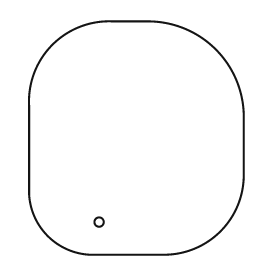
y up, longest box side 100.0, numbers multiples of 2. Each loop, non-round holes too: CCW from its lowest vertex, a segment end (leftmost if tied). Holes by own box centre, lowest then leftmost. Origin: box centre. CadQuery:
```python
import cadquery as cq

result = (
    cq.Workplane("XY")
    .moveTo(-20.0, -50.0)
    .lineTo(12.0, -50.0)
    .threePointArc((36.0, -40.0), (46.0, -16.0))
    .lineTo(46.0, 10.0)
    .threePointArc((34.0, 38.0), (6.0, 50.0))
    .lineTo(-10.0, 50.0)
    .threePointArc((-36.0, 40.0), (-46.0, 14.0))
    .lineTo(-46.0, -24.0)
    .threePointArc((-38.0, -42.0), (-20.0, -50.0))
    .close()
    .moveTo(-16.0, -36.0)
    .circle(2.0)
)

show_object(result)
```